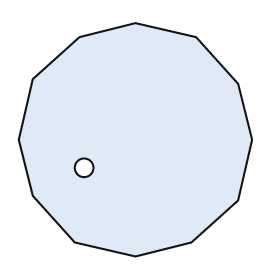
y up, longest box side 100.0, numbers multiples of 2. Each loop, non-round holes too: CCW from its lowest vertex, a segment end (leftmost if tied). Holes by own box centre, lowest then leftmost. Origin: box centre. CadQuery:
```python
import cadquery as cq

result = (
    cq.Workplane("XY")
    .moveTo(0.0, -50.0)
    .lineTo(24.0, -44.0)
    .lineTo(44.0, -26.0)
    .lineTo(50.0, 0.0)
    .lineTo(44.0, 24.0)
    .lineTo(26.0, 44.0)
    .lineTo(0.0, 50.0)
    .lineTo(-24.0, 44.0)
    .lineTo(-44.0, 26.0)
    .lineTo(-50.0, 0.0)
    .lineTo(-44.0, -24.0)
    .lineTo(-26.0, -44.0)
    .close()
    .moveTo(-22.0, -12.0)
    .circle(4.0)
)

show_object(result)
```